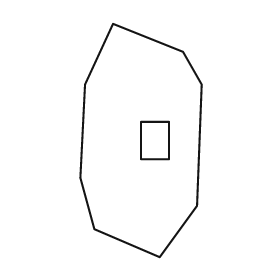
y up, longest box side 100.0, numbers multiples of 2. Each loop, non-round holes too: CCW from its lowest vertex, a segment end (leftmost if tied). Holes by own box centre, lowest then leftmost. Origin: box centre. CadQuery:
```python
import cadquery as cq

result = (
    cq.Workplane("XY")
    .moveTo(8.0, -50.0)
    .lineTo(24.0, -28.0)
    .lineTo(26.0, 24.0)
    .lineTo(18.0, 38.0)
    .lineTo(-12.0, 50.0)
    .lineTo(-24.0, 24.0)
    .lineTo(-26.0, -16.0)
    .lineTo(-20.0, -38.0)
    .close()
    .moveTo(0.0, -8.0)
    .lineTo(12.0, -8.0)
    .lineTo(12.0, 8.0)
    .lineTo(0.0, 8.0)
    .close()
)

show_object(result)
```